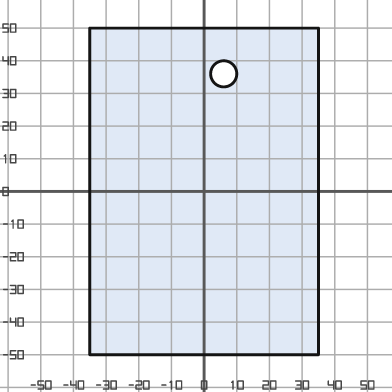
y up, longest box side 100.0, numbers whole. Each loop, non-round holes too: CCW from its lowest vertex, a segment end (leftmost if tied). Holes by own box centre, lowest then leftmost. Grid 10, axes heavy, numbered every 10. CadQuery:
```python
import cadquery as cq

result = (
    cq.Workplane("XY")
    .moveTo(-35.0, -50.0)
    .lineTo(35.0, -50.0)
    .lineTo(35.0, 50.0)
    .lineTo(-35.0, 50.0)
    .close()
    .moveTo(6.0, 36.0)
    .circle(4.0)
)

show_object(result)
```